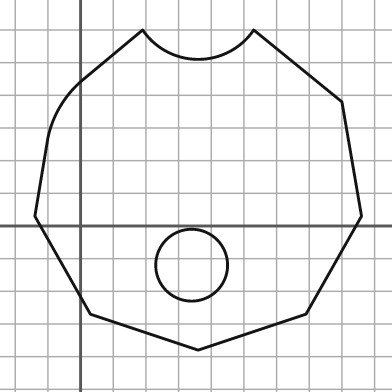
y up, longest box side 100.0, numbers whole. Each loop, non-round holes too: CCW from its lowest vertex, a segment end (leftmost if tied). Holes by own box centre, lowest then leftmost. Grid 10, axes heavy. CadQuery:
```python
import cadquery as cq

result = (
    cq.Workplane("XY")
    .moveTo(36.0, -38.0)
    .lineTo(69.0, -27.0)
    .lineTo(86.0, 3.0)
    .lineTo(80.0, 38.0)
    .lineTo(53.0, 60.0)
    .threePointArc((36.0, 51.0), (19.0, 60.0))
    .lineTo(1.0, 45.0)
    .threePointArc((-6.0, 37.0), (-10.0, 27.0))
    .lineTo(-14.0, 3.0)
    .lineTo(3.0, -27.0)
    .close()
    .moveTo(34.0, -12.0)
    .circle(11.0)
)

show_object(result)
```